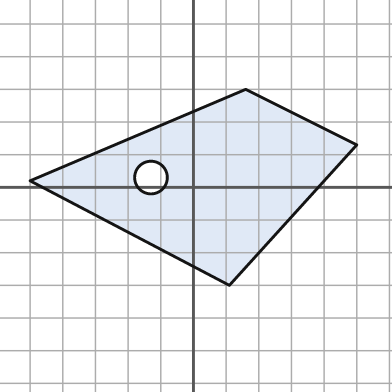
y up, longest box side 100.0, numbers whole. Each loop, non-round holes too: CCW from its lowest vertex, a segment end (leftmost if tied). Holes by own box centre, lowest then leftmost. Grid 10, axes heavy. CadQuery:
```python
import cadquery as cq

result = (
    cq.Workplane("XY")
    .moveTo(11.0, -30.0)
    .lineTo(50.0, 13.0)
    .lineTo(16.0, 30.0)
    .lineTo(-50.0, 2.0)
    .close()
    .moveTo(-13.0, 3.0)
    .circle(5.0)
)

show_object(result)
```